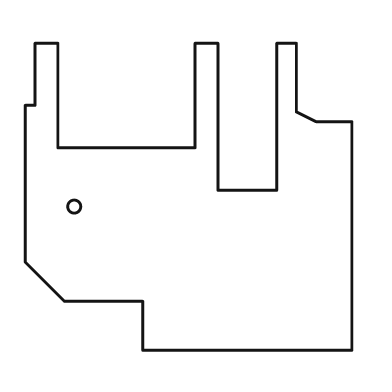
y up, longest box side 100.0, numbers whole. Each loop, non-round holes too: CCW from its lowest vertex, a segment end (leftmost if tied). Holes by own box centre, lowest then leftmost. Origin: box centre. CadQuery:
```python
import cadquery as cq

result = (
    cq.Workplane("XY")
    .moveTo(-14.0, -47.0)
    .lineTo(50.0, -47.0)
    .lineTo(50.0, 23.0)
    .lineTo(39.0, 23.0)
    .lineTo(33.0, 26.0)
    .lineTo(33.0, 47.0)
    .lineTo(27.0, 47.0)
    .lineTo(27.0, 2.0)
    .lineTo(9.0, 2.0)
    .lineTo(9.0, 47.0)
    .lineTo(2.0, 47.0)
    .lineTo(2.0, 15.0)
    .lineTo(-40.0, 15.0)
    .lineTo(-40.0, 47.0)
    .lineTo(-47.0, 47.0)
    .lineTo(-47.0, 28.0)
    .lineTo(-50.0, 28.0)
    .lineTo(-50.0, -20.0)
    .lineTo(-38.0, -32.0)
    .lineTo(-14.0, -32.0)
    .close()
    .moveTo(-35.0, -3.0)
    .circle(2.0)
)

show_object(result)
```